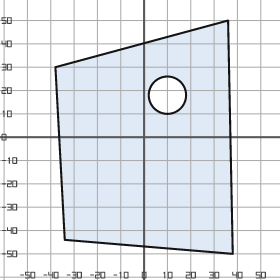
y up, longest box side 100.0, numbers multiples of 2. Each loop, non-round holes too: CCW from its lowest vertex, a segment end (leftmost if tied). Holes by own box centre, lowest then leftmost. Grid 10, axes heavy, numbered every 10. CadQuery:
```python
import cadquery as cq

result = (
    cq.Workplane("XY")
    .moveTo(38.0, -50.0)
    .lineTo(36.0, 50.0)
    .lineTo(-38.0, 30.0)
    .lineTo(-34.0, -44.0)
    .close()
    .moveTo(10.0, 18.0)
    .circle(8.0)
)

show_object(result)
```